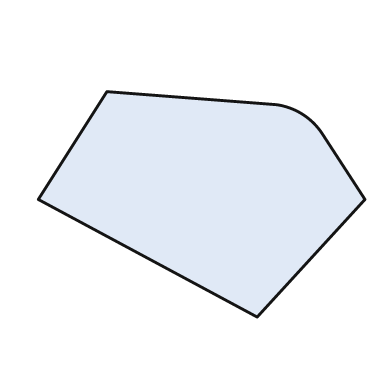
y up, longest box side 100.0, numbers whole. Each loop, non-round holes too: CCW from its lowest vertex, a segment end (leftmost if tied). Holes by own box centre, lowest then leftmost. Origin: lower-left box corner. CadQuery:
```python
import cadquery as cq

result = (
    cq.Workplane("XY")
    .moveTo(67.0, 0.0)
    .lineTo(100.0, 36.0)
    .lineTo(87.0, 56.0)
    .threePointArc((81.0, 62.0), (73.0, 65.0))
    .lineTo(21.0, 69.0)
    .lineTo(0.0, 36.0)
    .close()
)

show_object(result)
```